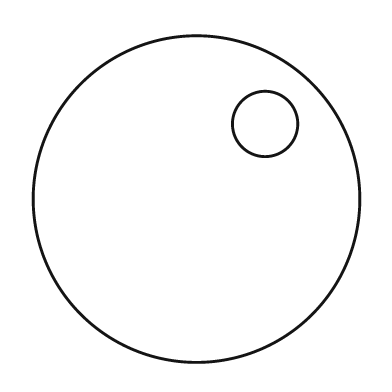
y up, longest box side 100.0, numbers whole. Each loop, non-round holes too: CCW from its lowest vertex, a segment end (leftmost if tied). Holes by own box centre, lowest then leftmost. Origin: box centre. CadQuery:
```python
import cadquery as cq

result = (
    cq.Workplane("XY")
    .moveTo(0.0, 0.0)
    .circle(50.0)
    .moveTo(21.0, 23.0)
    .circle(10.0)
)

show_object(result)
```